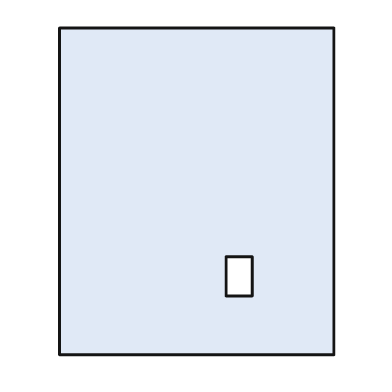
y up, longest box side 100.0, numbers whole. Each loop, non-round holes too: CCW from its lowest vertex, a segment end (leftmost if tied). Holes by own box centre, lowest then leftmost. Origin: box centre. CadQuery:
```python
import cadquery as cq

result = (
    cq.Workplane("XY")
    .moveTo(-42.0, -50.0)
    .lineTo(42.0, -50.0)
    .lineTo(42.0, 50.0)
    .lineTo(-42.0, 50.0)
    .close()
    .moveTo(9.0, -32.0)
    .lineTo(17.0, -32.0)
    .lineTo(17.0, -20.0)
    .lineTo(9.0, -20.0)
    .close()
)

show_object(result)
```